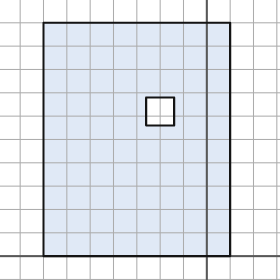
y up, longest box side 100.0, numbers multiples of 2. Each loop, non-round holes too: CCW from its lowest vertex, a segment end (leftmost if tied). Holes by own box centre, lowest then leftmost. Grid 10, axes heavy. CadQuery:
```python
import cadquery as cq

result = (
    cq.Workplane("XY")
    .moveTo(-70.0, 0.0)
    .lineTo(10.0, 0.0)
    .lineTo(10.0, 100.0)
    .lineTo(-70.0, 100.0)
    .close()
    .moveTo(-26.0, 56.0)
    .lineTo(-14.0, 56.0)
    .lineTo(-14.0, 68.0)
    .lineTo(-26.0, 68.0)
    .close()
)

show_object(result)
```